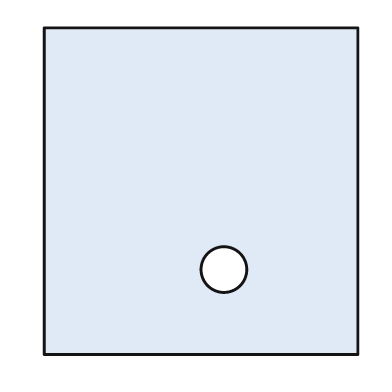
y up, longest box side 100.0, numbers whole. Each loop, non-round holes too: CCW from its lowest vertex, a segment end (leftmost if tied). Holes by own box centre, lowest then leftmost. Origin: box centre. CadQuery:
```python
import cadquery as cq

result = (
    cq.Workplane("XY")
    .moveTo(-48.0, -50.0)
    .lineTo(48.0, -50.0)
    .lineTo(48.0, 50.0)
    .lineTo(-48.0, 50.0)
    .close()
    .moveTo(7.0, -24.0)
    .circle(7.0)
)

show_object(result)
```